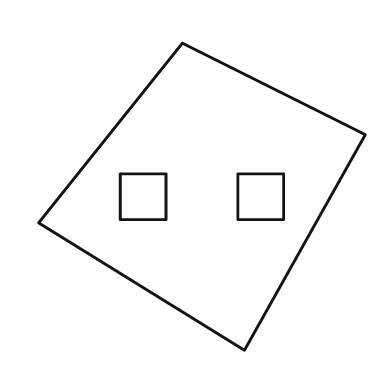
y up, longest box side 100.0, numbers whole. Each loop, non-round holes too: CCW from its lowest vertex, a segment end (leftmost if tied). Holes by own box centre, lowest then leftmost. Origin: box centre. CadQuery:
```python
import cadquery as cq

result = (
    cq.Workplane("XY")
    .moveTo(13.0, -47.0)
    .lineTo(50.0, 19.0)
    .lineTo(-6.0, 47.0)
    .lineTo(-50.0, -8.0)
    .close()
    .moveTo(-25.0, -7.0)
    .lineTo(-11.0, -7.0)
    .lineTo(-11.0, 7.0)
    .lineTo(-25.0, 7.0)
    .close()
    .moveTo(11.0, -7.0)
    .lineTo(25.0, -7.0)
    .lineTo(25.0, 7.0)
    .lineTo(11.0, 7.0)
    .close()
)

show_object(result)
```